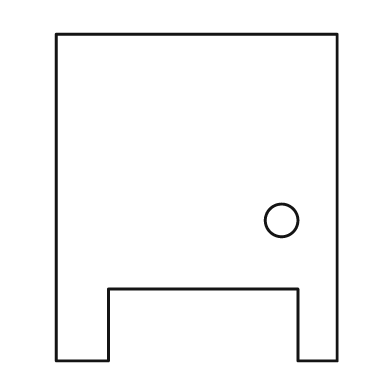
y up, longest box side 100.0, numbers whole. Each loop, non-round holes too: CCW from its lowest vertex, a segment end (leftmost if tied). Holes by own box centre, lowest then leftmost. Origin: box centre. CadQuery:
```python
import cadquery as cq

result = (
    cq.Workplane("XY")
    .moveTo(-43.0, -50.0)
    .lineTo(-27.0, -50.0)
    .lineTo(-27.0, -28.0)
    .lineTo(31.0, -28.0)
    .lineTo(31.0, -50.0)
    .lineTo(43.0, -50.0)
    .lineTo(43.0, 50.0)
    .lineTo(-43.0, 50.0)
    .close()
    .moveTo(26.0, -7.0)
    .circle(5.0)
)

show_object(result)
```